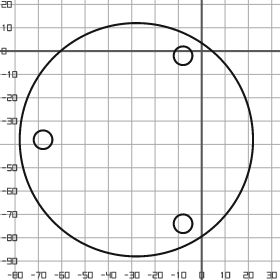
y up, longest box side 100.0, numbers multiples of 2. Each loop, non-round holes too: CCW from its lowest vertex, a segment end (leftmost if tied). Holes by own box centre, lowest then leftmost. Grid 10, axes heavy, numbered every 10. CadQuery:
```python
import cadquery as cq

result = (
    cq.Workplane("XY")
    .moveTo(-28.0, -38.0)
    .circle(50.0)
    .moveTo(-8.0, -74.0)
    .circle(4.0)
    .moveTo(-68.0, -38.0)
    .circle(4.0)
    .moveTo(-8.0, -2.0)
    .circle(4.0)
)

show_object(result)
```